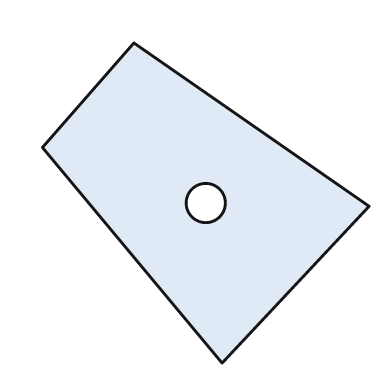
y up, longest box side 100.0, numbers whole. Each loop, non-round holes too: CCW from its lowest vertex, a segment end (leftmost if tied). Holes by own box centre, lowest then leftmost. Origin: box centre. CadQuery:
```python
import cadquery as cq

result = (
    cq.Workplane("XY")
    .moveTo(5.0, -49.0)
    .lineTo(50.0, -1.0)
    .lineTo(-22.0, 49.0)
    .lineTo(-50.0, 17.0)
    .close()
    .moveTo(0.0, 0.0)
    .circle(6.0)
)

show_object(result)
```